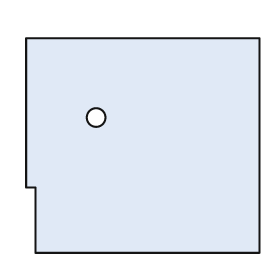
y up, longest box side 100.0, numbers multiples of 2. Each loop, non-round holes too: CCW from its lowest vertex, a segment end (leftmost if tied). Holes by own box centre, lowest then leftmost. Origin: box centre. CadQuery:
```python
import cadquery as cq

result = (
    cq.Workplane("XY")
    .moveTo(-46.0, -46.0)
    .lineTo(50.0, -46.0)
    .lineTo(50.0, 46.0)
    .lineTo(-50.0, 46.0)
    .lineTo(-50.0, -18.0)
    .lineTo(-46.0, -18.0)
    .close()
    .moveTo(-20.0, 12.0)
    .circle(4.0)
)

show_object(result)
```